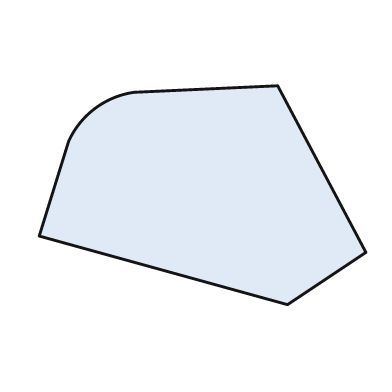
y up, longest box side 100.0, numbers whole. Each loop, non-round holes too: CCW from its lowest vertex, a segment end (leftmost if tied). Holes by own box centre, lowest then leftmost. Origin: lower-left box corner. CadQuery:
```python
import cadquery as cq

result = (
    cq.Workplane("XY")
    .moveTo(76.0, 0.0)
    .lineTo(100.0, 16.0)
    .lineTo(73.0, 67.0)
    .lineTo(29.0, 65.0)
    .threePointArc((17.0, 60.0), (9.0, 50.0))
    .lineTo(0.0, 21.0)
    .close()
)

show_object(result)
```